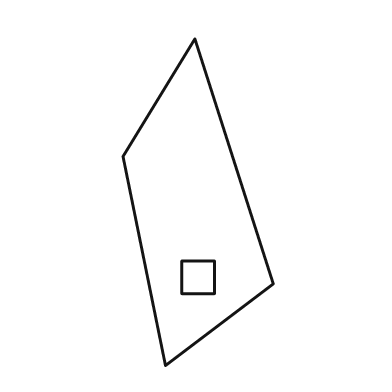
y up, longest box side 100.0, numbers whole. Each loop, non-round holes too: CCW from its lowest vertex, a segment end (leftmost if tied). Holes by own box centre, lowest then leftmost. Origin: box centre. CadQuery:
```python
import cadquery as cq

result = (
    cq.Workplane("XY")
    .moveTo(-10.0, -50.0)
    .lineTo(23.0, -25.0)
    .lineTo(-1.0, 50.0)
    .lineTo(-23.0, 14.0)
    .close()
    .moveTo(-5.0, -28.0)
    .lineTo(5.0, -28.0)
    .lineTo(5.0, -18.0)
    .lineTo(-5.0, -18.0)
    .close()
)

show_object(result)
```